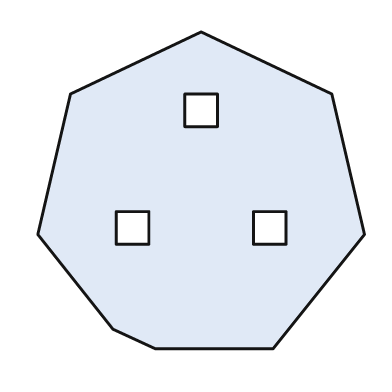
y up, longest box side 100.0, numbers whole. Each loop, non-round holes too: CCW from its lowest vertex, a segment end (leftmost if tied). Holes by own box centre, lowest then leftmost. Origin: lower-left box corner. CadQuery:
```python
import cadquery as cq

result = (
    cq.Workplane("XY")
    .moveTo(36.0, 0.0)
    .lineTo(72.0, 0.0)
    .lineTo(100.0, 35.0)
    .lineTo(90.0, 78.0)
    .lineTo(50.0, 97.0)
    .lineTo(10.0, 78.0)
    .lineTo(0.0, 35.0)
    .lineTo(23.0, 6.0)
    .close()
    .moveTo(24.0, 32.0)
    .lineTo(34.0, 32.0)
    .lineTo(34.0, 42.0)
    .lineTo(24.0, 42.0)
    .close()
    .moveTo(66.0, 32.0)
    .lineTo(76.0, 32.0)
    .lineTo(76.0, 42.0)
    .lineTo(66.0, 42.0)
    .close()
    .moveTo(45.0, 68.0)
    .lineTo(55.0, 68.0)
    .lineTo(55.0, 78.0)
    .lineTo(45.0, 78.0)
    .close()
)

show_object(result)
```